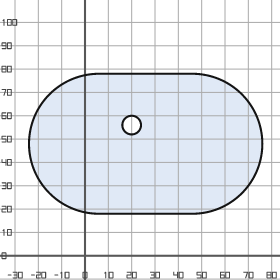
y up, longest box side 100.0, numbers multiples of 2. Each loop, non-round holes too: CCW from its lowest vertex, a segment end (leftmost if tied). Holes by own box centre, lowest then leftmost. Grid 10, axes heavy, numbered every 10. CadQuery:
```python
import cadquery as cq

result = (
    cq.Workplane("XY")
    .moveTo(6.0, 18.0)
    .lineTo(46.0, 18.0)
    .threePointArc((76.0, 48.0), (46.0, 78.0))
    .lineTo(6.0, 78.0)
    .threePointArc((-24.0, 48.0), (6.0, 18.0))
    .close()
    .moveTo(20.0, 56.0)
    .circle(4.0)
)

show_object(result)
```